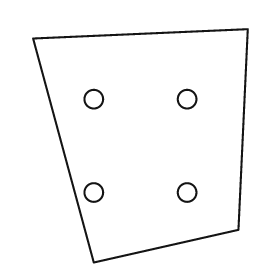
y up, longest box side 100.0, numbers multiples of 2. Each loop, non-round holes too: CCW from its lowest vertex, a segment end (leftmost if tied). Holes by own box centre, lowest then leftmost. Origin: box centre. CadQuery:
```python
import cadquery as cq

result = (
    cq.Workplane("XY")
    .moveTo(-20.0, -50.0)
    .lineTo(42.0, -36.0)
    .lineTo(46.0, 50.0)
    .lineTo(-46.0, 46.0)
    .close()
    .moveTo(-20.0, -20.0)
    .circle(4.0)
    .moveTo(20.0, -20.0)
    .circle(4.0)
    .moveTo(-20.0, 20.0)
    .circle(4.0)
    .moveTo(20.0, 20.0)
    .circle(4.0)
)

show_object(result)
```